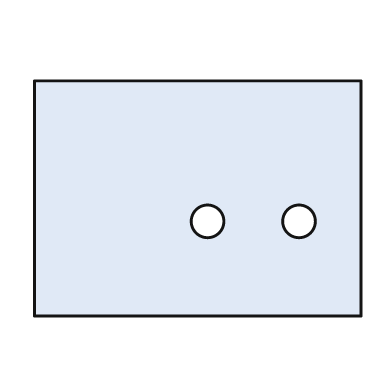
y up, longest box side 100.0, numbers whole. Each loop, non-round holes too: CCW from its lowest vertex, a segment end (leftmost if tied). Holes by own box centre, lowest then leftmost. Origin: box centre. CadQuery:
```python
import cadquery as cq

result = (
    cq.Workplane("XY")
    .moveTo(-50.0, -36.0)
    .lineTo(50.0, -36.0)
    .lineTo(50.0, 36.0)
    .lineTo(-50.0, 36.0)
    .close()
    .moveTo(3.0, -7.0)
    .circle(5.0)
    .moveTo(31.0, -7.0)
    .circle(5.0)
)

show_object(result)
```